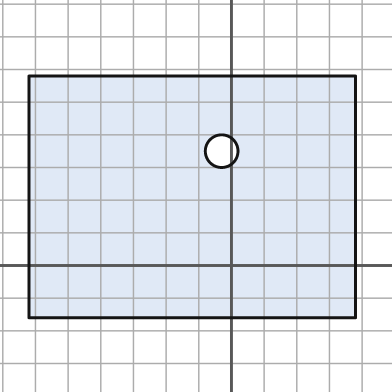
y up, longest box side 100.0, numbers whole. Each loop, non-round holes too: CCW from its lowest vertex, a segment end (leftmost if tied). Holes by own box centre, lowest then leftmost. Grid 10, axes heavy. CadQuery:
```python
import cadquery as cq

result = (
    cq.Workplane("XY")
    .moveTo(-62.0, -16.0)
    .lineTo(38.0, -16.0)
    .lineTo(38.0, 58.0)
    .lineTo(-62.0, 58.0)
    .close()
    .moveTo(-3.0, 35.0)
    .circle(5.0)
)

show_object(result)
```